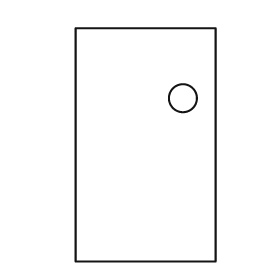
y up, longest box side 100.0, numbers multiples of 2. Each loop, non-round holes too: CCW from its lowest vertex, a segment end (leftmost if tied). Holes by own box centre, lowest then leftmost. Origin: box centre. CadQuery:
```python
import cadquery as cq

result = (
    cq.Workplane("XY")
    .moveTo(-30.0, -50.0)
    .lineTo(30.0, -50.0)
    .lineTo(30.0, 50.0)
    .lineTo(-30.0, 50.0)
    .close()
    .moveTo(16.0, 20.0)
    .circle(6.0)
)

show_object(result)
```